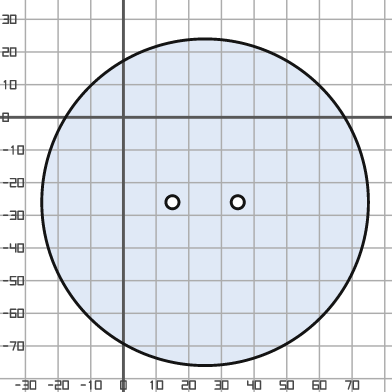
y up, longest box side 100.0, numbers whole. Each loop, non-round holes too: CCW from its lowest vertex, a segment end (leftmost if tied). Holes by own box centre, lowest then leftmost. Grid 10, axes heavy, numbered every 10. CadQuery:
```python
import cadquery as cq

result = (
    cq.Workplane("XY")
    .moveTo(25.0, -26.0)
    .circle(50.0)
    .moveTo(15.0, -26.0)
    .circle(2.0)
    .moveTo(35.0, -26.0)
    .circle(2.0)
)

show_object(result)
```